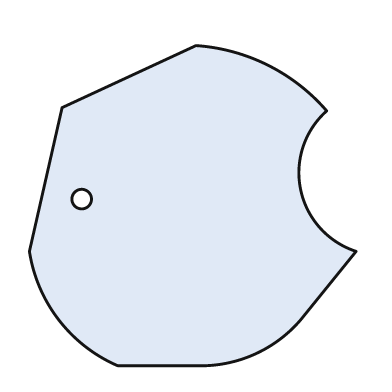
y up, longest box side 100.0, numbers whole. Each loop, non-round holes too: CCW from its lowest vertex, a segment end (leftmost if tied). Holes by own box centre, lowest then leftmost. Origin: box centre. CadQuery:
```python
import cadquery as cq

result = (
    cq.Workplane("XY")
    .moveTo(-23.0, -49.0)
    .lineTo(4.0, -49.0)
    .threePointArc((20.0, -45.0), (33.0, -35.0))
    .lineTo(50.0, -14.0)
    .threePointArc((33.0, 5.0), (41.0, 29.0))
    .threePointArc((23.0, 43.0), (1.0, 49.0))
    .lineTo(-40.0, 30.0)
    .lineTo(-50.0, -14.0)
    .threePointArc((-41.0, -35.0), (-23.0, -49.0))
    .close()
    .moveTo(-34.0, 2.0)
    .circle(3.0)
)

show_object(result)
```